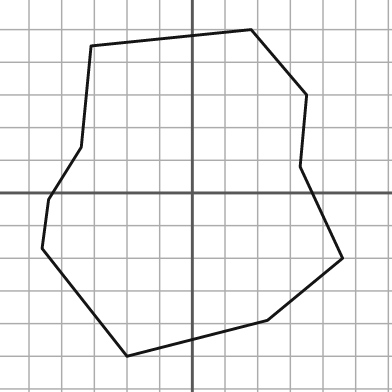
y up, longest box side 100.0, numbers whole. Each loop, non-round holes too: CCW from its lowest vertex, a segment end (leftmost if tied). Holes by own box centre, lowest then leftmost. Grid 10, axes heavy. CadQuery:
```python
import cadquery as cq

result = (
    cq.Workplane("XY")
    .moveTo(-20.0, -50.0)
    .lineTo(23.0, -39.0)
    .lineTo(46.0, -20.0)
    .lineTo(33.0, 8.0)
    .lineTo(35.0, 30.0)
    .lineTo(18.0, 50.0)
    .lineTo(-31.0, 45.0)
    .lineTo(-34.0, 14.0)
    .lineTo(-44.0, -2.0)
    .lineTo(-46.0, -17.0)
    .close()
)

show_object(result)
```